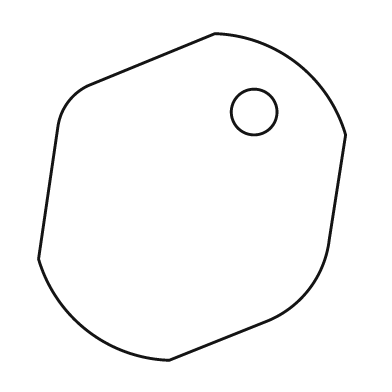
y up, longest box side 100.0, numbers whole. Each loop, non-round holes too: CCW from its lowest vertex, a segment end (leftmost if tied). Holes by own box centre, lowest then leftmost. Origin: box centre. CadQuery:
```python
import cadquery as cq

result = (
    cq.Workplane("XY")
    .moveTo(-7.0, -50.0)
    .lineTo(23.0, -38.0)
    .threePointArc((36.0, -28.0), (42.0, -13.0))
    .lineTo(47.0, 19.0)
    .threePointArc((32.0, 41.0), (7.0, 50.0))
    .lineTo(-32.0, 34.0)
    .threePointArc((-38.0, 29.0), (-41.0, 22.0))
    .lineTo(-47.0, -19.0)
    .threePointArc((-32.0, -41.0), (-7.0, -50.0))
    .close()
    .moveTo(19.0, 26.0)
    .circle(7.0)
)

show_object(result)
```